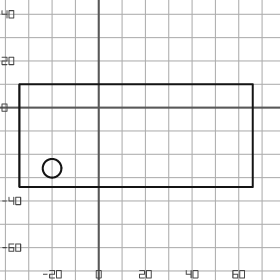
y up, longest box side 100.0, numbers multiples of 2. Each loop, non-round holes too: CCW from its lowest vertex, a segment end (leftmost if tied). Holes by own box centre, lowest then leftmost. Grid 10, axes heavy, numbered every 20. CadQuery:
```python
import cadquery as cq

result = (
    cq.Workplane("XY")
    .moveTo(-34.0, -34.0)
    .lineTo(66.0, -34.0)
    .lineTo(66.0, 10.0)
    .lineTo(-34.0, 10.0)
    .close()
    .moveTo(-20.0, -26.0)
    .circle(4.0)
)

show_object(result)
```